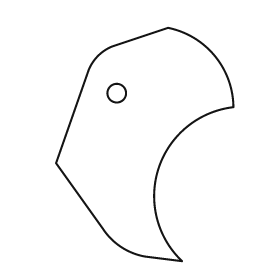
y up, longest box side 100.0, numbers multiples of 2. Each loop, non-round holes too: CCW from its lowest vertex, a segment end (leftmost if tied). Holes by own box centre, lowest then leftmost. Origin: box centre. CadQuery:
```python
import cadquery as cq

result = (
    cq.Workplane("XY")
    .moveTo(16.0, -50.0)
    .threePointArc((6.0, -10.0), (38.0, 16.0))
    .threePointArc((30.0, 38.0), (10.0, 50.0))
    .lineTo(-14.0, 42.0)
    .threePointArc((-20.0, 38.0), (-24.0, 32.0))
    .lineTo(-38.0, -8.0)
    .lineTo(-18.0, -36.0)
    .threePointArc((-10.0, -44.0), (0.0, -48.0))
    .close()
    .moveTo(-12.0, 22.0)
    .circle(4.0)
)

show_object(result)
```